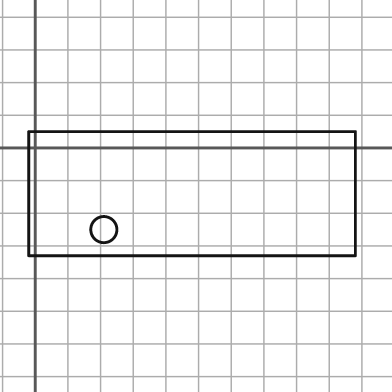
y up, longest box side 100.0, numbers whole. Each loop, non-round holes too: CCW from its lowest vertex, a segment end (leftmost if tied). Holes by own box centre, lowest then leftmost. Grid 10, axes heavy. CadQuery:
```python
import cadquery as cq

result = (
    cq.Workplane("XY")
    .moveTo(-2.0, -33.0)
    .lineTo(98.0, -33.0)
    .lineTo(98.0, 5.0)
    .lineTo(-2.0, 5.0)
    .close()
    .moveTo(21.0, -25.0)
    .circle(4.0)
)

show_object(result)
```